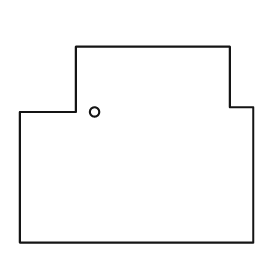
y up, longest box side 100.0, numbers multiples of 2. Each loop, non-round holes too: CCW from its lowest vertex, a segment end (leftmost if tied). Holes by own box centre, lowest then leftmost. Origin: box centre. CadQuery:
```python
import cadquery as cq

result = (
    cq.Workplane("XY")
    .moveTo(-50.0, -42.0)
    .lineTo(50.0, -42.0)
    .lineTo(50.0, 16.0)
    .lineTo(40.0, 16.0)
    .lineTo(40.0, 42.0)
    .lineTo(-26.0, 42.0)
    .lineTo(-26.0, 14.0)
    .lineTo(-50.0, 14.0)
    .close()
    .moveTo(-18.0, 14.0)
    .circle(2.0)
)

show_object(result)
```